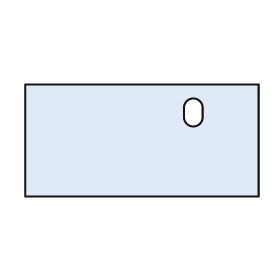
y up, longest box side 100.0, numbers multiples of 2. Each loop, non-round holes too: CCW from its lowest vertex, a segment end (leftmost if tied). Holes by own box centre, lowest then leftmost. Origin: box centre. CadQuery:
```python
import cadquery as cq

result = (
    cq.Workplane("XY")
    .moveTo(-50.0, -24.0)
    .lineTo(50.0, -24.0)
    .lineTo(50.0, 24.0)
    .lineTo(-50.0, 24.0)
    .close()
    .moveTo(18.0, 10.0)
    .threePointArc((22.0, 6.0), (26.0, 10.0))
    .lineTo(26.0, 14.0)
    .threePointArc((22.0, 18.0), (18.0, 14.0))
    .close()
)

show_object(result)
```